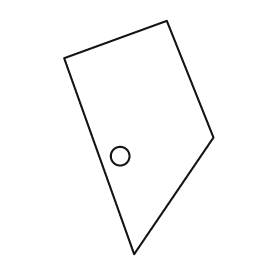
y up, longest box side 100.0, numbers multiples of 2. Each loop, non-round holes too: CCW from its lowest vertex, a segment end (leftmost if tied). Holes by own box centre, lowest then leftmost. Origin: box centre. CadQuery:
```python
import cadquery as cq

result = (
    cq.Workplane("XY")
    .moveTo(-2.0, -50.0)
    .lineTo(32.0, 0.0)
    .lineTo(12.0, 50.0)
    .lineTo(-32.0, 34.0)
    .close()
    .moveTo(-8.0, -8.0)
    .circle(4.0)
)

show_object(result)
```